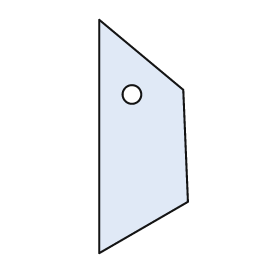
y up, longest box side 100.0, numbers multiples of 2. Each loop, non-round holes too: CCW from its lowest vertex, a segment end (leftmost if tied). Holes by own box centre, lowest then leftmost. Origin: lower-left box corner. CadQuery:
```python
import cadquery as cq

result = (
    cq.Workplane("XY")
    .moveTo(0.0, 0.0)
    .lineTo(38.0, 22.0)
    .lineTo(36.0, 70.0)
    .lineTo(0.0, 100.0)
    .close()
    .moveTo(14.0, 68.0)
    .circle(4.0)
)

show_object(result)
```